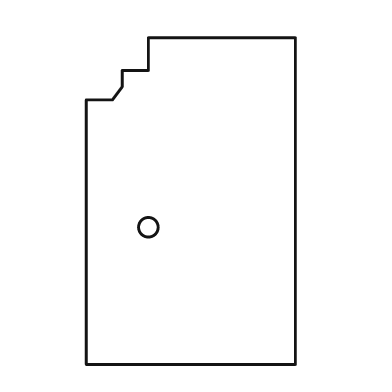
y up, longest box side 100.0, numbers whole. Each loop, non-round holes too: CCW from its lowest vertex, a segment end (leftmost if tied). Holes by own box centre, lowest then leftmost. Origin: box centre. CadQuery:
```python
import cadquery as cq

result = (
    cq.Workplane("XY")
    .moveTo(-32.0, -50.0)
    .lineTo(32.0, -50.0)
    .lineTo(32.0, 50.0)
    .lineTo(-13.0, 50.0)
    .lineTo(-13.0, 40.0)
    .lineTo(-21.0, 40.0)
    .lineTo(-21.0, 35.0)
    .lineTo(-24.0, 31.0)
    .lineTo(-32.0, 31.0)
    .close()
    .moveTo(-13.0, -8.0)
    .circle(3.0)
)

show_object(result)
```